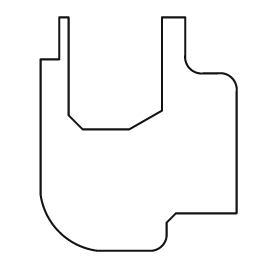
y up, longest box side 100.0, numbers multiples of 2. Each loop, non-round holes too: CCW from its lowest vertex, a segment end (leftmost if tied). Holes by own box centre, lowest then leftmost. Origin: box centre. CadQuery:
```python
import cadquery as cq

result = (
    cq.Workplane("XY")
    .moveTo(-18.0, -50.0)
    .lineTo(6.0, -50.0)
    .threePointArc((10.0, -48.0), (12.0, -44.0))
    .lineTo(12.0, -38.0)
    .lineTo(16.0, -34.0)
    .lineTo(42.0, -34.0)
    .lineTo(42.0, 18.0)
    .threePointArc((40.0, 24.0), (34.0, 26.0))
    .lineTo(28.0, 26.0)
    .threePointArc((22.0, 28.0), (20.0, 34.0))
    .lineTo(20.0, 50.0)
    .lineTo(10.0, 50.0)
    .lineTo(10.0, 10.0)
    .lineTo(-4.0, 2.0)
    .lineTo(-24.0, 2.0)
    .lineTo(-30.0, 8.0)
    .lineTo(-30.0, 50.0)
    .lineTo(-34.0, 50.0)
    .lineTo(-34.0, 32.0)
    .lineTo(-42.0, 32.0)
    .lineTo(-42.0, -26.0)
    .threePointArc((-34.0, -42.0), (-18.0, -50.0))
    .close()
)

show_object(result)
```